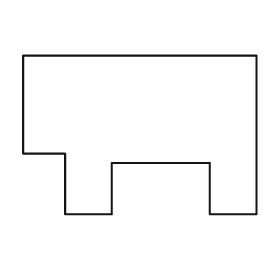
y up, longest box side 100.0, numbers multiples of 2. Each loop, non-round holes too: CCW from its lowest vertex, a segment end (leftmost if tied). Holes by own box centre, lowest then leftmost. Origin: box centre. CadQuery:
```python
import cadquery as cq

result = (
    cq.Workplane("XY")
    .moveTo(-32.0, -34.0)
    .lineTo(-12.0, -34.0)
    .lineTo(-12.0, -12.0)
    .lineTo(30.0, -12.0)
    .lineTo(30.0, -34.0)
    .lineTo(50.0, -34.0)
    .lineTo(50.0, 34.0)
    .lineTo(-50.0, 34.0)
    .lineTo(-50.0, -8.0)
    .lineTo(-32.0, -8.0)
    .close()
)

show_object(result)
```